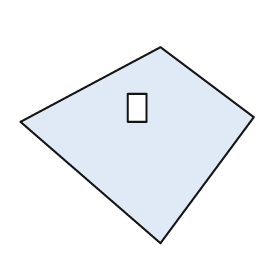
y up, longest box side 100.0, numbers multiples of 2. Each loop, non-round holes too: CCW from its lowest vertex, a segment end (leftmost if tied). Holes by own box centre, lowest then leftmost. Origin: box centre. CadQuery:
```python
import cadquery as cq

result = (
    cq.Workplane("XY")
    .moveTo(10.0, -42.0)
    .lineTo(50.0, 12.0)
    .lineTo(10.0, 42.0)
    .lineTo(-50.0, 10.0)
    .close()
    .moveTo(-4.0, 10.0)
    .lineTo(4.0, 10.0)
    .lineTo(4.0, 22.0)
    .lineTo(-4.0, 22.0)
    .close()
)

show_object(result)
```